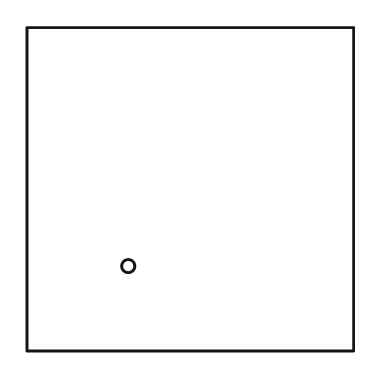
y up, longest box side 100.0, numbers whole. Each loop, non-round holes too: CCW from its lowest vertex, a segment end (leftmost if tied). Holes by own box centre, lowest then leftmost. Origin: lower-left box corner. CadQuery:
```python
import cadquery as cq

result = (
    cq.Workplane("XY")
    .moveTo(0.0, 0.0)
    .lineTo(100.0, 0.0)
    .lineTo(100.0, 99.0)
    .lineTo(0.0, 99.0)
    .close()
    .moveTo(31.0, 26.0)
    .circle(2.0)
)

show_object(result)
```